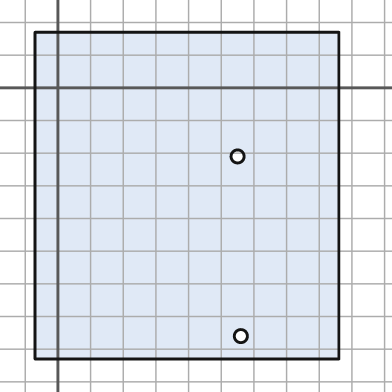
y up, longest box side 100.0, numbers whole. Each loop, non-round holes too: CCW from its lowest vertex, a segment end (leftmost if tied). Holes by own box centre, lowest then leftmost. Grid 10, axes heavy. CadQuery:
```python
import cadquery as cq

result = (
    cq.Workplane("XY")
    .moveTo(-7.0, -83.0)
    .lineTo(86.0, -83.0)
    .lineTo(86.0, 17.0)
    .lineTo(-7.0, 17.0)
    .close()
    .moveTo(56.0, -76.0)
    .circle(2.0)
    .moveTo(55.0, -21.0)
    .circle(2.0)
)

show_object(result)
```